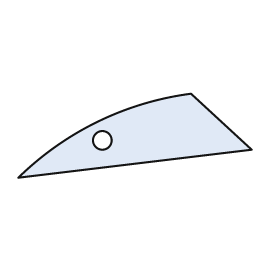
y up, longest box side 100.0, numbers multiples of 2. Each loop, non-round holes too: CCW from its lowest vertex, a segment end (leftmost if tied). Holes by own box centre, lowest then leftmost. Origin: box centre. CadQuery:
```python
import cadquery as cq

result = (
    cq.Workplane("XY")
    .moveTo(-50.0, -18.0)
    .lineTo(50.0, -6.0)
    .lineTo(24.0, 18.0)
    .threePointArc((-16.0, 6.0), (-50.0, -18.0))
    .close()
    .moveTo(-14.0, -2.0)
    .circle(4.0)
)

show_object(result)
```